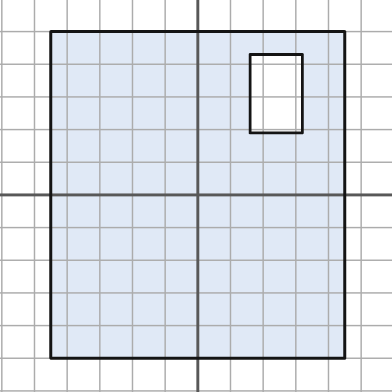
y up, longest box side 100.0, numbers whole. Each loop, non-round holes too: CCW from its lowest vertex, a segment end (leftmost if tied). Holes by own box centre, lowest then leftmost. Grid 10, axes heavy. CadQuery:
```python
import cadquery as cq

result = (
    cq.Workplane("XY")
    .moveTo(-45.0, -50.0)
    .lineTo(45.0, -50.0)
    .lineTo(45.0, 50.0)
    .lineTo(-45.0, 50.0)
    .close()
    .moveTo(16.0, 19.0)
    .lineTo(32.0, 19.0)
    .lineTo(32.0, 43.0)
    .lineTo(16.0, 43.0)
    .close()
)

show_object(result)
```